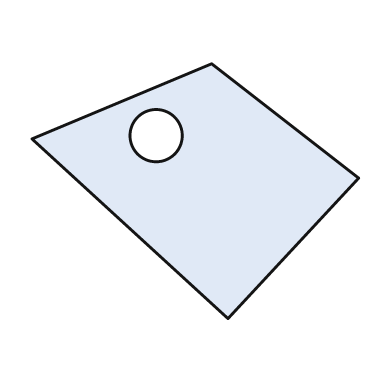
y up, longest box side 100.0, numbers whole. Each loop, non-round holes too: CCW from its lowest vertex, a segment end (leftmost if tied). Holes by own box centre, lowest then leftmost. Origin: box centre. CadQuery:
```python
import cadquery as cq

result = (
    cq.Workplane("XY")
    .moveTo(10.0, -39.0)
    .lineTo(50.0, 4.0)
    .lineTo(5.0, 39.0)
    .lineTo(-50.0, 16.0)
    .close()
    .moveTo(-12.0, 17.0)
    .circle(8.0)
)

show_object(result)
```